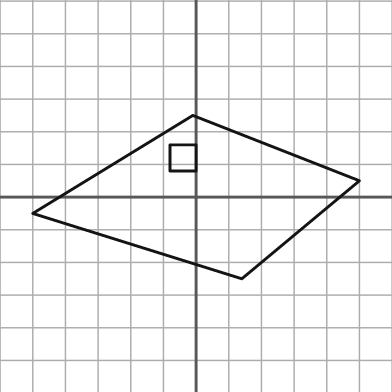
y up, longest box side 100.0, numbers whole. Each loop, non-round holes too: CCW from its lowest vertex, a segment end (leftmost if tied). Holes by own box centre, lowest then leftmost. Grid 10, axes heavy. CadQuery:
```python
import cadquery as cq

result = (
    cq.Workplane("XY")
    .moveTo(14.0, -25.0)
    .lineTo(50.0, 5.0)
    .lineTo(-1.0, 25.0)
    .lineTo(-50.0, -5.0)
    .close()
    .moveTo(-8.0, 8.0)
    .lineTo(0.0, 8.0)
    .lineTo(0.0, 16.0)
    .lineTo(-8.0, 16.0)
    .close()
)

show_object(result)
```